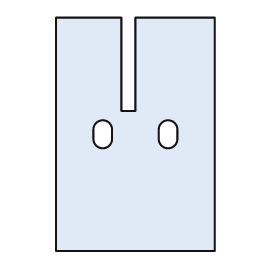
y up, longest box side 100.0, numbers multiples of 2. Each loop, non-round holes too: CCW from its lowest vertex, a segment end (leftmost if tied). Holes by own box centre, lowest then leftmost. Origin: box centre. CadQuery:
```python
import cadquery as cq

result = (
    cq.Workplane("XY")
    .moveTo(-34.0, -50.0)
    .lineTo(34.0, -50.0)
    .lineTo(34.0, 50.0)
    .lineTo(0.0, 50.0)
    .lineTo(0.0, 10.0)
    .lineTo(-6.0, 10.0)
    .lineTo(-6.0, 50.0)
    .lineTo(-34.0, 50.0)
    .close()
    .moveTo(-18.0, -2.0)
    .threePointArc((-14.0, -6.0), (-10.0, -2.0))
    .lineTo(-10.0, 2.0)
    .threePointArc((-14.0, 6.0), (-18.0, 2.0))
    .close()
    .moveTo(10.0, -2.0)
    .threePointArc((14.0, -6.0), (18.0, -2.0))
    .lineTo(18.0, 2.0)
    .threePointArc((14.0, 6.0), (10.0, 2.0))
    .close()
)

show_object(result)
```